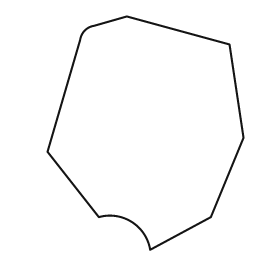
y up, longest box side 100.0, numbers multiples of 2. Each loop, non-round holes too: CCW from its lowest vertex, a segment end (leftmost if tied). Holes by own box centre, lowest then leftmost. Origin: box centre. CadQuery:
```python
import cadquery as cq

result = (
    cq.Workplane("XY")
    .moveTo(2.0, -50.0)
    .lineTo(28.0, -36.0)
    .lineTo(42.0, -2.0)
    .lineTo(36.0, 38.0)
    .lineTo(-8.0, 50.0)
    .lineTo(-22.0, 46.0)
    .threePointArc((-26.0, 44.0), (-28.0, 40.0))
    .lineTo(-42.0, -8.0)
    .lineTo(-20.0, -36.0)
    .threePointArc((-6.0, -38.0), (2.0, -50.0))
    .close()
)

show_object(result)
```